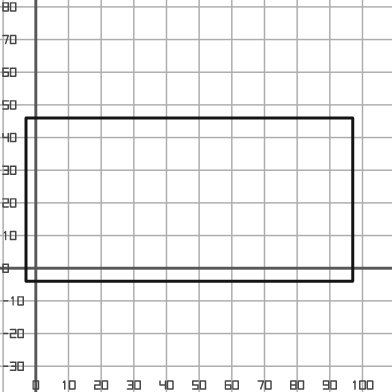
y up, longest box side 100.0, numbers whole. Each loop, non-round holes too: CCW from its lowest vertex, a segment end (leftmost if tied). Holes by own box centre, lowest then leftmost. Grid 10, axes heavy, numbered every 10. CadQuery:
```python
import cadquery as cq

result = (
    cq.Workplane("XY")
    .moveTo(-3.0, -4.0)
    .lineTo(97.0, -4.0)
    .lineTo(97.0, 46.0)
    .lineTo(-3.0, 46.0)
    .close()
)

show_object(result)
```